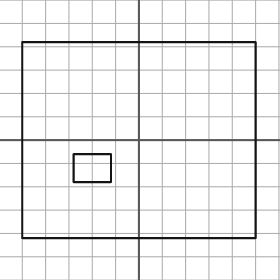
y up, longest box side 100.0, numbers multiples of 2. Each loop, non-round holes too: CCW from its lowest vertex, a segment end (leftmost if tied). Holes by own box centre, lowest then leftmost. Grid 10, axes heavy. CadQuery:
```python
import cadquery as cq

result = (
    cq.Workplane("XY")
    .moveTo(-50.0, -42.0)
    .lineTo(50.0, -42.0)
    .lineTo(50.0, 42.0)
    .lineTo(-50.0, 42.0)
    .close()
    .moveTo(-28.0, -18.0)
    .lineTo(-12.0, -18.0)
    .lineTo(-12.0, -6.0)
    .lineTo(-28.0, -6.0)
    .close()
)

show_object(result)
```